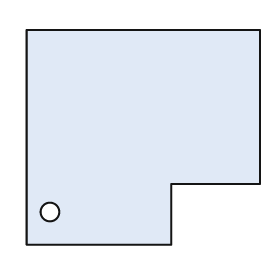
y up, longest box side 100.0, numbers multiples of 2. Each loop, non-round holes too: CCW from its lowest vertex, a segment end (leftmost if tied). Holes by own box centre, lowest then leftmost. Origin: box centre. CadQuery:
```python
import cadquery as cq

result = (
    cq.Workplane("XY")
    .moveTo(-50.0, -46.0)
    .lineTo(12.0, -46.0)
    .lineTo(12.0, -20.0)
    .lineTo(50.0, -20.0)
    .lineTo(50.0, 46.0)
    .lineTo(-50.0, 46.0)
    .close()
    .moveTo(-40.0, -32.0)
    .circle(4.0)
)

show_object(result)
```